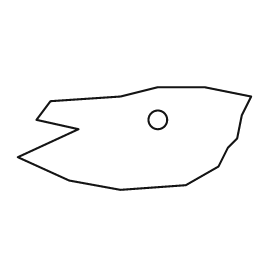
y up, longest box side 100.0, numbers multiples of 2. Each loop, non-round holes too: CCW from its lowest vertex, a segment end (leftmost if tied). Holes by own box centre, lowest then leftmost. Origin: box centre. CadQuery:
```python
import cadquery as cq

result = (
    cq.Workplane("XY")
    .moveTo(-6.0, -22.0)
    .lineTo(22.0, -20.0)
    .lineTo(36.0, -12.0)
    .lineTo(40.0, -4.0)
    .lineTo(44.0, 0.0)
    .lineTo(46.0, 10.0)
    .lineTo(50.0, 18.0)
    .lineTo(30.0, 22.0)
    .lineTo(10.0, 22.0)
    .lineTo(-6.0, 18.0)
    .lineTo(-36.0, 16.0)
    .lineTo(-42.0, 8.0)
    .lineTo(-24.0, 4.0)
    .lineTo(-50.0, -8.0)
    .lineTo(-28.0, -18.0)
    .close()
    .moveTo(10.0, 8.0)
    .circle(4.0)
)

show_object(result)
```